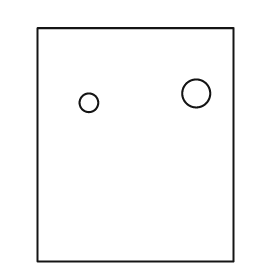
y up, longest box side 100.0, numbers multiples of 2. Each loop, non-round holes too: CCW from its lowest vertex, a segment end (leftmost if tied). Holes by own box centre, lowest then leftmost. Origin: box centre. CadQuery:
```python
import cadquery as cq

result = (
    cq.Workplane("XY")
    .moveTo(-42.0, -50.0)
    .lineTo(42.0, -50.0)
    .lineTo(42.0, 50.0)
    .lineTo(-42.0, 50.0)
    .close()
    .moveTo(-20.0, 18.0)
    .circle(4.0)
    .moveTo(26.0, 22.0)
    .circle(6.0)
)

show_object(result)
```